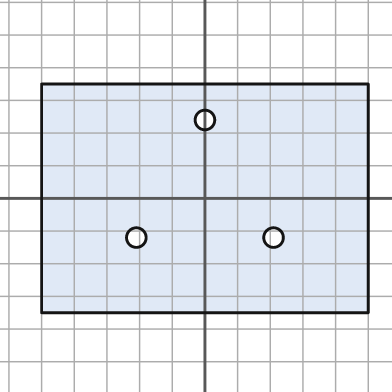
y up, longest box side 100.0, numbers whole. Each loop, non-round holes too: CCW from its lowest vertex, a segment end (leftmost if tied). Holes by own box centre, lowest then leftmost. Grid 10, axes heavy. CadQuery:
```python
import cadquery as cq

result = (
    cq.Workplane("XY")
    .moveTo(-50.0, -35.0)
    .lineTo(50.0, -35.0)
    .lineTo(50.0, 35.0)
    .lineTo(-50.0, 35.0)
    .close()
    .moveTo(-21.0, -12.0)
    .circle(3.0)
    .moveTo(21.0, -12.0)
    .circle(3.0)
    .moveTo(0.0, 24.0)
    .circle(3.0)
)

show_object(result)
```